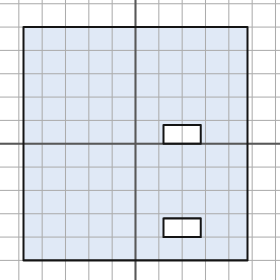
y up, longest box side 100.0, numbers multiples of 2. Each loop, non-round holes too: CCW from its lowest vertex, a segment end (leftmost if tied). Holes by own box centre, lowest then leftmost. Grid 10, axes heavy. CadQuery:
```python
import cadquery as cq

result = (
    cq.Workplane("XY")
    .moveTo(-48.0, -50.0)
    .lineTo(48.0, -50.0)
    .lineTo(48.0, 50.0)
    .lineTo(-48.0, 50.0)
    .close()
    .moveTo(12.0, -40.0)
    .lineTo(28.0, -40.0)
    .lineTo(28.0, -32.0)
    .lineTo(12.0, -32.0)
    .close()
    .moveTo(12.0, 0.0)
    .lineTo(28.0, 0.0)
    .lineTo(28.0, 8.0)
    .lineTo(12.0, 8.0)
    .close()
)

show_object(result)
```